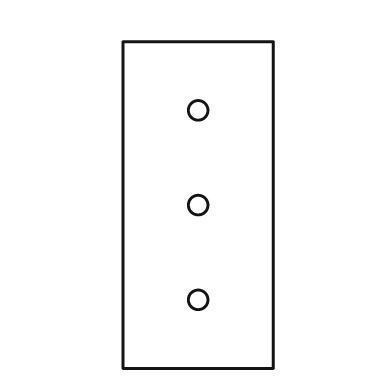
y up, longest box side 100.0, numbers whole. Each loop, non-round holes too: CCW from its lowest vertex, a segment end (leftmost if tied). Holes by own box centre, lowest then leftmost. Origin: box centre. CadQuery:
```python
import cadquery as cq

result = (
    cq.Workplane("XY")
    .moveTo(-23.0, -50.0)
    .lineTo(23.0, -50.0)
    .lineTo(23.0, 50.0)
    .lineTo(-23.0, 50.0)
    .close()
    .moveTo(0.0, -29.0)
    .circle(3.0)
    .moveTo(0.0, 0.0)
    .circle(3.0)
    .moveTo(0.0, 29.0)
    .circle(3.0)
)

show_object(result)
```